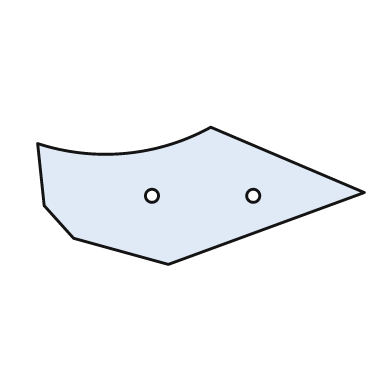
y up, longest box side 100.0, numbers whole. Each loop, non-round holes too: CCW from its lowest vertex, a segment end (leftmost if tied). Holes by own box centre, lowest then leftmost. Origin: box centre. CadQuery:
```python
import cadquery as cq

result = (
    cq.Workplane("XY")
    .moveTo(-10.0, -21.0)
    .lineTo(50.0, 1.0)
    .lineTo(3.0, 21.0)
    .threePointArc((-23.0, 13.0), (-50.0, 16.0))
    .lineTo(-48.0, -3.0)
    .lineTo(-39.0, -13.0)
    .close()
    .moveTo(-15.0, 0.0)
    .circle(2.0)
    .moveTo(16.0, 0.0)
    .circle(2.0)
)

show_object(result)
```